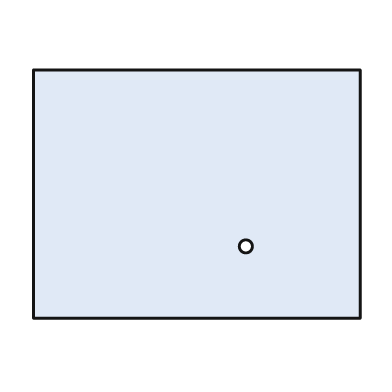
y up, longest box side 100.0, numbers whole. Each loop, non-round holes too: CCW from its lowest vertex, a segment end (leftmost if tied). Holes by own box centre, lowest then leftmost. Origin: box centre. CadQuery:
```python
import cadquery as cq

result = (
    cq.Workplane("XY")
    .moveTo(-50.0, -38.0)
    .lineTo(50.0, -38.0)
    .lineTo(50.0, 38.0)
    .lineTo(-50.0, 38.0)
    .close()
    .moveTo(15.0, -16.0)
    .circle(2.0)
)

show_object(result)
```